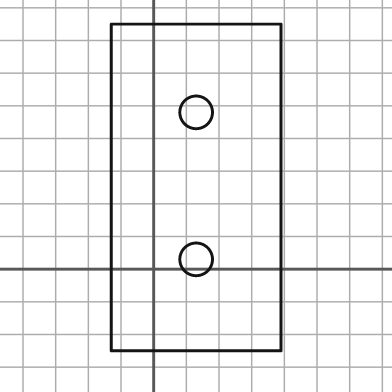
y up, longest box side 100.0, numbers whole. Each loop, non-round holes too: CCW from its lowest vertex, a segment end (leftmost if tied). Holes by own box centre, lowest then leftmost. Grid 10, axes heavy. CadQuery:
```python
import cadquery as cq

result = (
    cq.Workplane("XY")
    .moveTo(-13.0, -25.0)
    .lineTo(39.0, -25.0)
    .lineTo(39.0, 75.0)
    .lineTo(-13.0, 75.0)
    .close()
    .moveTo(13.0, 3.0)
    .circle(5.0)
    .moveTo(13.0, 48.0)
    .circle(5.0)
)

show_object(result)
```